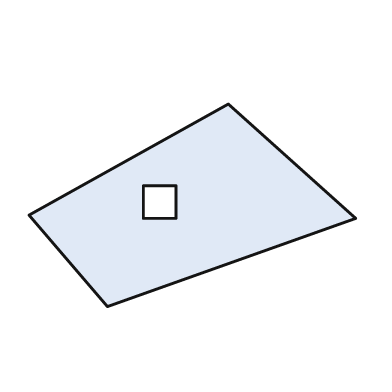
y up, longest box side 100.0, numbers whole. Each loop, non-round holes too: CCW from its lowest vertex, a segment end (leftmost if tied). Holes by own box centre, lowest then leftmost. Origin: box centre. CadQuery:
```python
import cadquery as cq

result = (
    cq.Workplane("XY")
    .moveTo(-26.0, -31.0)
    .lineTo(50.0, -4.0)
    .lineTo(11.0, 31.0)
    .lineTo(-50.0, -3.0)
    .close()
    .moveTo(-15.0, -4.0)
    .lineTo(-5.0, -4.0)
    .lineTo(-5.0, 6.0)
    .lineTo(-15.0, 6.0)
    .close()
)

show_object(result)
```